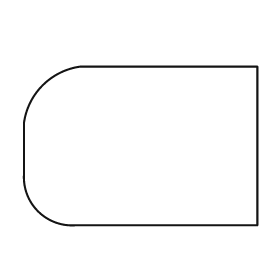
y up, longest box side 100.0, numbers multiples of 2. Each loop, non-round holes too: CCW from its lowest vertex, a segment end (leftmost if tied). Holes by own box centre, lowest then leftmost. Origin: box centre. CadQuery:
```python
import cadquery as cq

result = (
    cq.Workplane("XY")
    .moveTo(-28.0, -34.0)
    .lineTo(50.0, -34.0)
    .lineTo(50.0, 34.0)
    .lineTo(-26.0, 34.0)
    .threePointArc((-42.0, 26.0), (-50.0, 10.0))
    .lineTo(-50.0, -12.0)
    .threePointArc((-44.0, -28.0), (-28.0, -34.0))
    .close()
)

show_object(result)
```